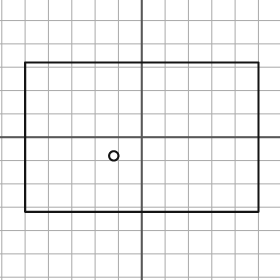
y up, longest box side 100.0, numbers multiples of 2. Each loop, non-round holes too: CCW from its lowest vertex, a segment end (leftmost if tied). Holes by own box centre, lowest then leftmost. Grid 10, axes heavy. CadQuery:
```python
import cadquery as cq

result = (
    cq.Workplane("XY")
    .moveTo(-50.0, -32.0)
    .lineTo(50.0, -32.0)
    .lineTo(50.0, 32.0)
    .lineTo(-50.0, 32.0)
    .close()
    .moveTo(-12.0, -8.0)
    .circle(2.0)
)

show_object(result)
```